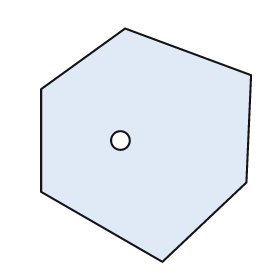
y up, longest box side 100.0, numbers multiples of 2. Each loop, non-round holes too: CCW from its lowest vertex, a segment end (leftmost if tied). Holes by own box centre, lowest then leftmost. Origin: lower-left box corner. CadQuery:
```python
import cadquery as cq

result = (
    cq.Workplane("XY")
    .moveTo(52.0, 0.0)
    .lineTo(88.0, 34.0)
    .lineTo(90.0, 80.0)
    .lineTo(36.0, 100.0)
    .lineTo(0.0, 74.0)
    .lineTo(0.0, 30.0)
    .close()
    .moveTo(34.0, 52.0)
    .circle(4.0)
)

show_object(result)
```